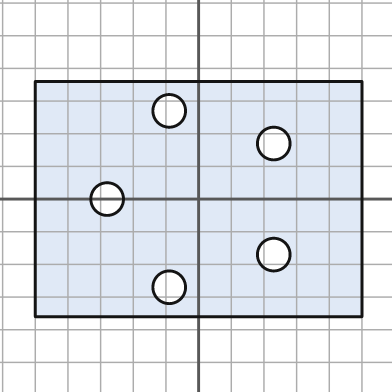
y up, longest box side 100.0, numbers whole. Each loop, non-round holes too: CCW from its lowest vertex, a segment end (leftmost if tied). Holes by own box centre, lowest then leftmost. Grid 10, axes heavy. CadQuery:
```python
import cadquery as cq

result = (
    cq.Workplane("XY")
    .moveTo(-50.0, -36.0)
    .lineTo(50.0, -36.0)
    .lineTo(50.0, 36.0)
    .lineTo(-50.0, 36.0)
    .close()
    .moveTo(-9.0, -27.0)
    .circle(5.0)
    .moveTo(23.0, -17.0)
    .circle(5.0)
    .moveTo(-28.0, 0.0)
    .circle(5.0)
    .moveTo(23.0, 17.0)
    .circle(5.0)
    .moveTo(-9.0, 27.0)
    .circle(5.0)
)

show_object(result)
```